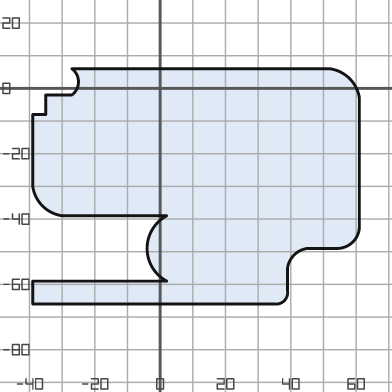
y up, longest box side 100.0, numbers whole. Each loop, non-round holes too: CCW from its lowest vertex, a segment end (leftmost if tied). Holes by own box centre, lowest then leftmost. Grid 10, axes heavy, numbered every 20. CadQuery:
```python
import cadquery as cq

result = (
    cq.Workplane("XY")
    .moveTo(-39.0, -66.0)
    .lineTo(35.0, -66.0)
    .threePointArc((38.0, -65.0), (39.0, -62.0))
    .lineTo(39.0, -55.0)
    .threePointArc((41.0, -51.0), (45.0, -49.0))
    .lineTo(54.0, -49.0)
    .threePointArc((59.0, -47.0), (61.0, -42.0))
    .lineTo(61.0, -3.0)
    .threePointArc((58.0, 3.0), (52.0, 6.0))
    .lineTo(-27.0, 6.0)
    .threePointArc((-25.0, 2.0), (-27.0, -2.0))
    .lineTo(-35.0, -2.0)
    .lineTo(-35.0, -8.0)
    .lineTo(-39.0, -8.0)
    .lineTo(-39.0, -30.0)
    .threePointArc((-36.0, -36.0), (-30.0, -39.0))
    .lineTo(2.0, -39.0)
    .threePointArc((-4.0, -49.0), (2.0, -59.0))
    .lineTo(-39.0, -59.0)
    .close()
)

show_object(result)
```